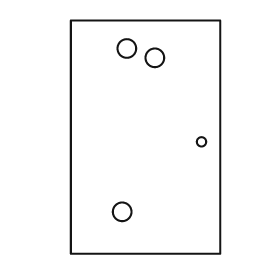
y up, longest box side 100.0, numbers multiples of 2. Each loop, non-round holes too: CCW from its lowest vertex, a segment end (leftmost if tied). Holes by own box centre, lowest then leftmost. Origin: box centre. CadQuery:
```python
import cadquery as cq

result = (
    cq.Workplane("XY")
    .moveTo(-32.0, -50.0)
    .lineTo(32.0, -50.0)
    .lineTo(32.0, 50.0)
    .lineTo(-32.0, 50.0)
    .close()
    .moveTo(-10.0, -32.0)
    .circle(4.0)
    .moveTo(24.0, -2.0)
    .circle(2.0)
    .moveTo(4.0, 34.0)
    .circle(4.0)
    .moveTo(-8.0, 38.0)
    .circle(4.0)
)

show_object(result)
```